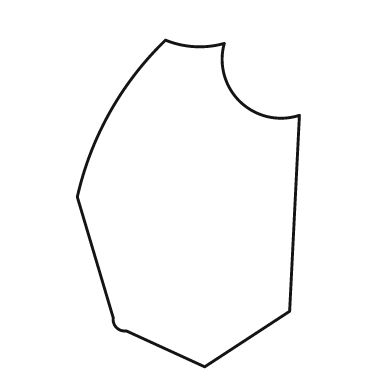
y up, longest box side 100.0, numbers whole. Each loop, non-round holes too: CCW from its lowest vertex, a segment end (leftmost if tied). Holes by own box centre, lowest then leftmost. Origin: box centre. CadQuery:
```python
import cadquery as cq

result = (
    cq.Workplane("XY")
    .moveTo(5.0, -50.0)
    .lineTo(31.0, -33.0)
    .lineTo(34.0, 27.0)
    .threePointArc((16.0, 31.0), (11.0, 49.0))
    .threePointArc((2.0, 48.0), (-7.0, 50.0))
    .threePointArc((-24.0, 28.0), (-34.0, 2.0))
    .lineTo(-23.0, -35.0)
    .threePointArc((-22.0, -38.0), (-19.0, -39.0))
    .close()
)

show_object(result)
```